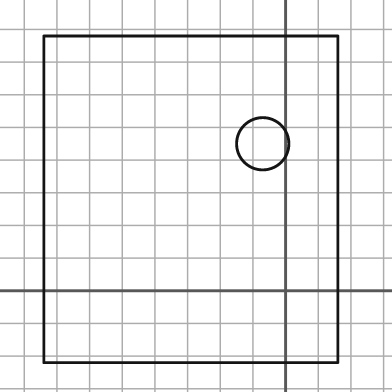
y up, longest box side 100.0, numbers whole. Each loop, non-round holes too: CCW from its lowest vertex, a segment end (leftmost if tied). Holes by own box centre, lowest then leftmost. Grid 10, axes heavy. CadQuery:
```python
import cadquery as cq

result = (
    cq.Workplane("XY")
    .moveTo(-74.0, -22.0)
    .lineTo(16.0, -22.0)
    .lineTo(16.0, 78.0)
    .lineTo(-74.0, 78.0)
    .close()
    .moveTo(-7.0, 45.0)
    .circle(8.0)
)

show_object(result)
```